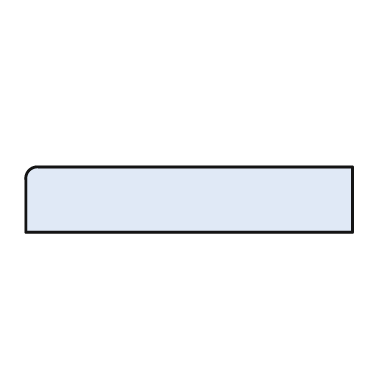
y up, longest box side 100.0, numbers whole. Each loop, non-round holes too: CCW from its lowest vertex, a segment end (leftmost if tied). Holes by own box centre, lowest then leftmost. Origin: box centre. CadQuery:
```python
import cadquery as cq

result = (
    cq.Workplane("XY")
    .moveTo(-50.0, -10.0)
    .lineTo(50.0, -10.0)
    .lineTo(50.0, 10.0)
    .lineTo(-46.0, 10.0)
    .threePointArc((-49.0, 9.0), (-50.0, 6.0))
    .close()
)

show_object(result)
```